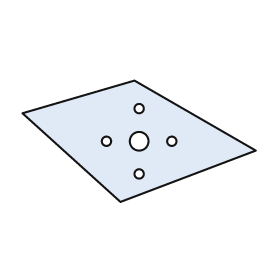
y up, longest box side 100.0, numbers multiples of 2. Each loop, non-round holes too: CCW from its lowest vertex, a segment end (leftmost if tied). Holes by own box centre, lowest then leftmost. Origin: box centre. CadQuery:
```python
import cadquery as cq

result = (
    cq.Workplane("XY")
    .moveTo(-8.0, -26.0)
    .lineTo(50.0, -4.0)
    .lineTo(-2.0, 26.0)
    .lineTo(-50.0, 12.0)
    .close()
    .moveTo(0.0, -14.0)
    .circle(2.0)
    .moveTo(-14.0, 0.0)
    .circle(2.0)
    .moveTo(0.0, 0.0)
    .circle(4.0)
    .moveTo(14.0, 0.0)
    .circle(2.0)
    .moveTo(0.0, 14.0)
    .circle(2.0)
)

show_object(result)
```